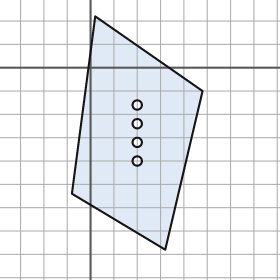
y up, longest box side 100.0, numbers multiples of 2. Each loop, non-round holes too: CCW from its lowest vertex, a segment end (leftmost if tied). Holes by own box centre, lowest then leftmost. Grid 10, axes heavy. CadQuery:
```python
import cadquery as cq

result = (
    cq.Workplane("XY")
    .moveTo(32.0, -78.0)
    .lineTo(48.0, -10.0)
    .lineTo(2.0, 22.0)
    .lineTo(-8.0, -54.0)
    .close()
    .moveTo(20.0, -40.0)
    .circle(2.0)
    .moveTo(20.0, -32.0)
    .circle(2.0)
    .moveTo(20.0, -24.0)
    .circle(2.0)
    .moveTo(20.0, -16.0)
    .circle(2.0)
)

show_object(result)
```